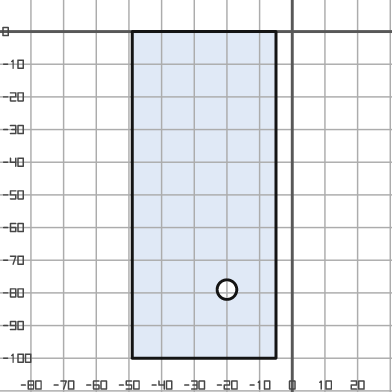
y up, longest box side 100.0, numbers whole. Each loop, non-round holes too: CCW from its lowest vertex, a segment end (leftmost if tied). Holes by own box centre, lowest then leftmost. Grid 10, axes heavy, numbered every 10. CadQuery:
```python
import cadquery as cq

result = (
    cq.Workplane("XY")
    .moveTo(-49.0, -100.0)
    .lineTo(-5.0, -100.0)
    .lineTo(-5.0, 0.0)
    .lineTo(-49.0, 0.0)
    .close()
    .moveTo(-20.0, -79.0)
    .circle(3.0)
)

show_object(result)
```